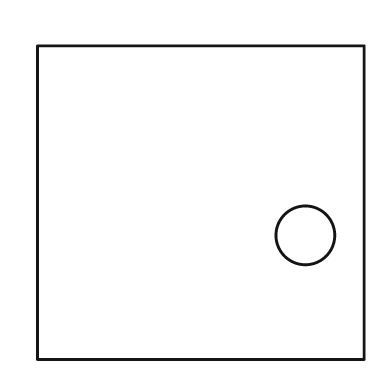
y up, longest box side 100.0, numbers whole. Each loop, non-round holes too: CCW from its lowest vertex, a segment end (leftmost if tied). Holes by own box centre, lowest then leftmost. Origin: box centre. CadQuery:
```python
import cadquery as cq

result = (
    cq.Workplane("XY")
    .moveTo(-50.0, -48.0)
    .lineTo(50.0, -48.0)
    .lineTo(50.0, 48.0)
    .lineTo(-50.0, 48.0)
    .close()
    .moveTo(32.0, -10.0)
    .circle(9.0)
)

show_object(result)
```